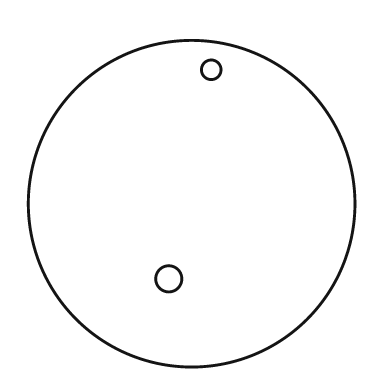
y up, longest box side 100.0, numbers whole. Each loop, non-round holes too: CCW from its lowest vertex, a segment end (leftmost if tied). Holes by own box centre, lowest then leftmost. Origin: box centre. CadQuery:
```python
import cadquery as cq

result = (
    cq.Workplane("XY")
    .moveTo(0.0, 0.0)
    .circle(50.0)
    .moveTo(-7.0, -23.0)
    .circle(4.0)
    .moveTo(6.0, 41.0)
    .circle(3.0)
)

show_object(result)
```